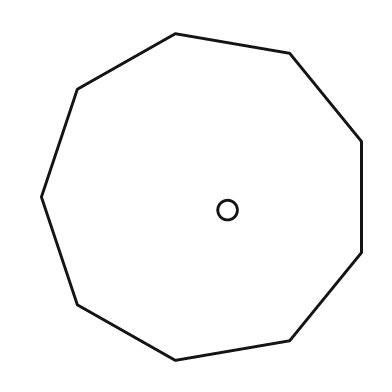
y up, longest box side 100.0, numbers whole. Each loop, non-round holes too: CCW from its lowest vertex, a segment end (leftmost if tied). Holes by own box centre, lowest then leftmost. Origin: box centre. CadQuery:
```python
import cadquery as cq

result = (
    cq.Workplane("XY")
    .moveTo(-8.0, -50.0)
    .lineTo(27.0, -44.0)
    .lineTo(49.0, -17.0)
    .lineTo(49.0, 17.0)
    .lineTo(27.0, 44.0)
    .lineTo(-8.0, 50.0)
    .lineTo(-38.0, 33.0)
    .lineTo(-49.0, 0.0)
    .lineTo(-38.0, -33.0)
    .close()
    .moveTo(8.0, -4.0)
    .circle(3.0)
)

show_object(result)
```